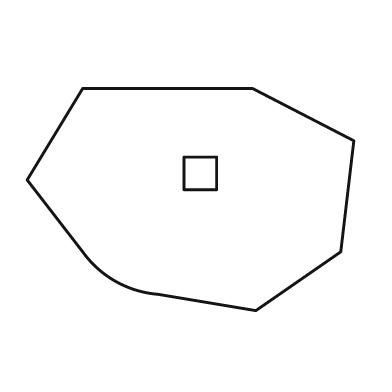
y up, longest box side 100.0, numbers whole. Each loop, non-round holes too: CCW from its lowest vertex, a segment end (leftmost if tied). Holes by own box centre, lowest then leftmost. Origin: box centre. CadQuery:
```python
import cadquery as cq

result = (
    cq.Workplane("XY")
    .moveTo(20.0, -34.0)
    .lineTo(46.0, -16.0)
    .lineTo(50.0, 18.0)
    .lineTo(19.0, 34.0)
    .lineTo(-33.0, 34.0)
    .lineTo(-50.0, 6.0)
    .lineTo(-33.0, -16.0)
    .threePointArc((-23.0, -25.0), (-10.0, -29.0))
    .close()
    .moveTo(-2.0, 3.0)
    .lineTo(8.0, 3.0)
    .lineTo(8.0, 13.0)
    .lineTo(-2.0, 13.0)
    .close()
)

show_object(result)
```